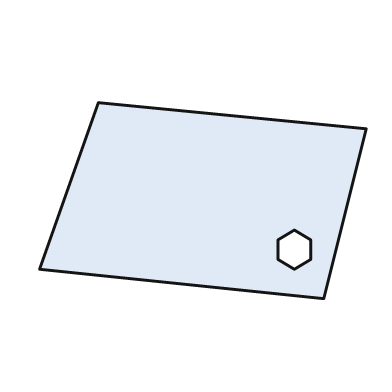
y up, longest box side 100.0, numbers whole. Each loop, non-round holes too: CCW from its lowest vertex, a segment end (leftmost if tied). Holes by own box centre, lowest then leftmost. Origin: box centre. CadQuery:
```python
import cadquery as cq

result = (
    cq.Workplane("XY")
    .moveTo(37.0, -30.0)
    .lineTo(50.0, 22.0)
    .lineTo(-32.0, 30.0)
    .lineTo(-50.0, -21.0)
    .close()
    .moveTo(28.0, -21.0)
    .lineTo(33.0, -18.0)
    .lineTo(33.0, -12.0)
    .lineTo(28.0, -9.0)
    .lineTo(23.0, -12.0)
    .lineTo(23.0, -18.0)
    .close()
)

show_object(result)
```